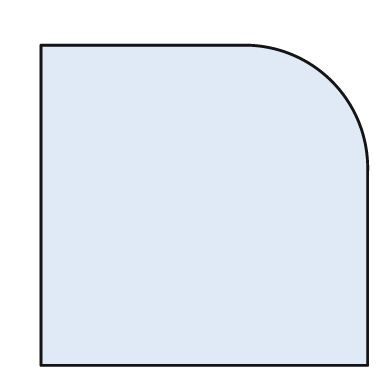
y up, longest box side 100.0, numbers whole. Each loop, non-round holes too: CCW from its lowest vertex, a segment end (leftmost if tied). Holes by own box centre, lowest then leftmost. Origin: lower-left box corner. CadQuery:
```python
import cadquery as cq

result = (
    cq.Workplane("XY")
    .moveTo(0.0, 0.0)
    .lineTo(100.0, 0.0)
    .lineTo(100.0, 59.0)
    .threePointArc((89.0, 87.0), (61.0, 98.0))
    .lineTo(0.0, 98.0)
    .close()
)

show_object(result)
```